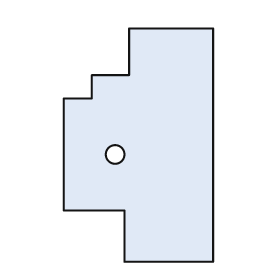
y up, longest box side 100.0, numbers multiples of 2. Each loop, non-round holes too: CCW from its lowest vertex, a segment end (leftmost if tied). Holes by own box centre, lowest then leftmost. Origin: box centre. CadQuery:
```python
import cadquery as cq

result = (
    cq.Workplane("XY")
    .moveTo(-6.0, -50.0)
    .lineTo(32.0, -50.0)
    .lineTo(32.0, 50.0)
    .lineTo(-4.0, 50.0)
    .lineTo(-4.0, 30.0)
    .lineTo(-20.0, 30.0)
    .lineTo(-20.0, 20.0)
    .lineTo(-32.0, 20.0)
    .lineTo(-32.0, -28.0)
    .lineTo(-6.0, -28.0)
    .close()
    .moveTo(-10.0, -4.0)
    .circle(4.0)
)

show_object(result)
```